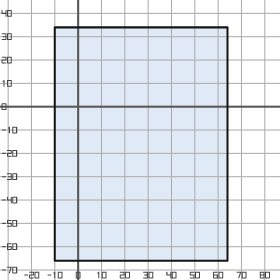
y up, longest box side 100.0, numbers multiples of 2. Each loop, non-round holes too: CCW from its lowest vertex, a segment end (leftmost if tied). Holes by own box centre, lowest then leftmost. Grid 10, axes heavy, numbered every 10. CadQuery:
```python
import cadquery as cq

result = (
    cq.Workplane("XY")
    .moveTo(-10.0, -66.0)
    .lineTo(64.0, -66.0)
    .lineTo(64.0, 34.0)
    .lineTo(-10.0, 34.0)
    .close()
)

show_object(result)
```